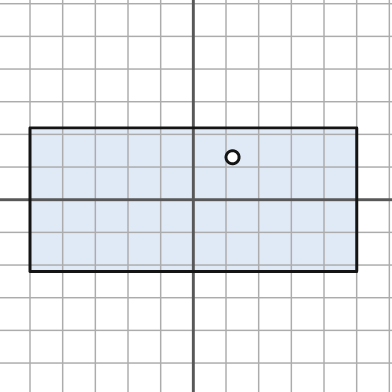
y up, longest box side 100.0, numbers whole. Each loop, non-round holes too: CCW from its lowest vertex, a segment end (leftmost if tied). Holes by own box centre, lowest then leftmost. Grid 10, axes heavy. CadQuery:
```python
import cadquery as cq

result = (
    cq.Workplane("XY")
    .moveTo(-50.0, -22.0)
    .lineTo(50.0, -22.0)
    .lineTo(50.0, 22.0)
    .lineTo(-50.0, 22.0)
    .close()
    .moveTo(12.0, 13.0)
    .circle(2.0)
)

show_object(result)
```